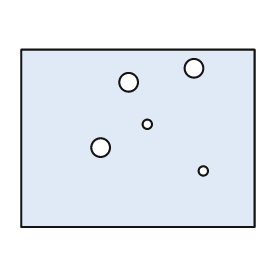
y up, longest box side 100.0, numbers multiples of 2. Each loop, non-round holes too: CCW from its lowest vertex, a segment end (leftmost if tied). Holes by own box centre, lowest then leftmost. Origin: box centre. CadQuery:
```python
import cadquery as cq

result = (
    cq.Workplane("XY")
    .moveTo(-50.0, -38.0)
    .lineTo(50.0, -38.0)
    .lineTo(50.0, 38.0)
    .lineTo(-50.0, 38.0)
    .close()
    .moveTo(28.0, -14.0)
    .circle(2.0)
    .moveTo(-16.0, -4.0)
    .circle(4.0)
    .moveTo(4.0, 6.0)
    .circle(2.0)
    .moveTo(-4.0, 24.0)
    .circle(4.0)
    .moveTo(24.0, 30.0)
    .circle(4.0)
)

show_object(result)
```